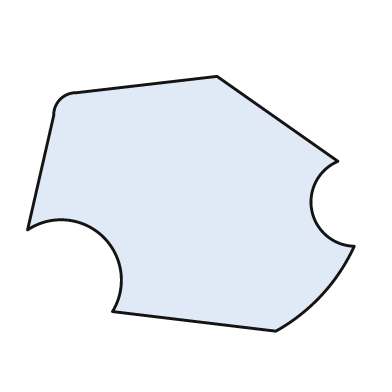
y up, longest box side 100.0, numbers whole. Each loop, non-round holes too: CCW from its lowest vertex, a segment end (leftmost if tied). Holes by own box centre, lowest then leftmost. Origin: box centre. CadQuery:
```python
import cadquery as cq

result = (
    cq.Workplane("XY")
    .moveTo(26.0, -39.0)
    .threePointArc((40.0, -28.0), (50.0, -13.0))
    .threePointArc((37.0, -2.0), (45.0, 13.0))
    .lineTo(8.0, 39.0)
    .lineTo(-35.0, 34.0)
    .threePointArc((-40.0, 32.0), (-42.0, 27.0))
    .lineTo(-50.0, -8.0)
    .threePointArc((-27.0, -10.0), (-24.0, -33.0))
    .close()
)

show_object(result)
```